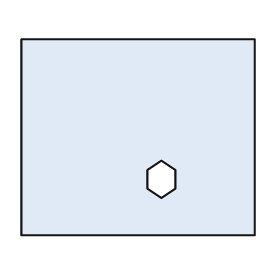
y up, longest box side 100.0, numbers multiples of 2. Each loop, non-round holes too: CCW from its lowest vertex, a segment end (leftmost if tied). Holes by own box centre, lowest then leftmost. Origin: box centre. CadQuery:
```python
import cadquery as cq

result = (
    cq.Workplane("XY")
    .moveTo(-50.0, -42.0)
    .lineTo(50.0, -42.0)
    .lineTo(50.0, 42.0)
    .lineTo(-50.0, 42.0)
    .close()
    .moveTo(10.0, -26.0)
    .lineTo(16.0, -22.0)
    .lineTo(16.0, -14.0)
    .lineTo(10.0, -10.0)
    .lineTo(4.0, -14.0)
    .lineTo(4.0, -22.0)
    .close()
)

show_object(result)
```